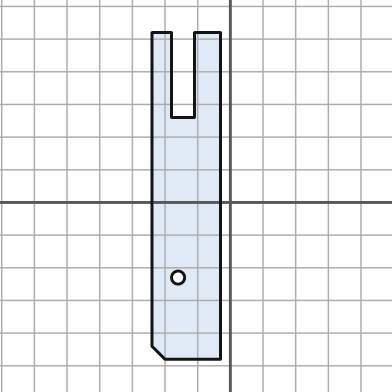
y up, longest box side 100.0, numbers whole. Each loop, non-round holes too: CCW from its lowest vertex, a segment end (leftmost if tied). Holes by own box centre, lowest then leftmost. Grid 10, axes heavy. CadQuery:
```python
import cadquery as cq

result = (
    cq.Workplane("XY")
    .moveTo(-20.0, -48.0)
    .lineTo(-3.0, -48.0)
    .lineTo(-3.0, 52.0)
    .lineTo(-11.0, 52.0)
    .lineTo(-11.0, 26.0)
    .lineTo(-18.0, 26.0)
    .lineTo(-18.0, 52.0)
    .lineTo(-24.0, 52.0)
    .lineTo(-24.0, -44.0)
    .close()
    .moveTo(-16.0, -23.0)
    .circle(2.0)
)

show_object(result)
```